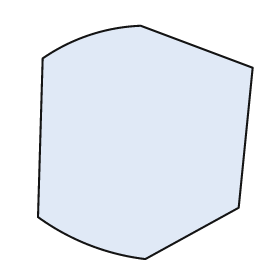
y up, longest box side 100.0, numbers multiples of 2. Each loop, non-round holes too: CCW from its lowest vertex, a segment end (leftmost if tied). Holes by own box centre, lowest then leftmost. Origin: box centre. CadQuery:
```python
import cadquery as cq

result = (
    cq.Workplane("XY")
    .moveTo(0.0, -50.0)
    .lineTo(40.0, -28.0)
    .lineTo(46.0, 32.0)
    .lineTo(-2.0, 50.0)
    .threePointArc((-24.0, 46.0), (-44.0, 36.0))
    .lineTo(-46.0, -32.0)
    .threePointArc((-24.0, -44.0), (0.0, -50.0))
    .close()
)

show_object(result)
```